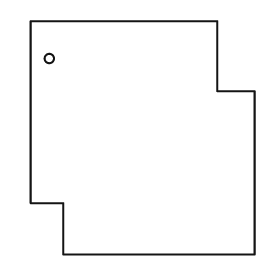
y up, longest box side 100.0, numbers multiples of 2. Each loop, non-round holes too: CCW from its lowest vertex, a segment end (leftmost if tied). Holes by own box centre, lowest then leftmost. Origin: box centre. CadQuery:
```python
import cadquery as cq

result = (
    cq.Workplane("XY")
    .moveTo(-34.0, -50.0)
    .lineTo(48.0, -50.0)
    .lineTo(48.0, 20.0)
    .lineTo(32.0, 20.0)
    .lineTo(32.0, 50.0)
    .lineTo(-48.0, 50.0)
    .lineTo(-48.0, -28.0)
    .lineTo(-34.0, -28.0)
    .close()
    .moveTo(-40.0, 34.0)
    .circle(2.0)
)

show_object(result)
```